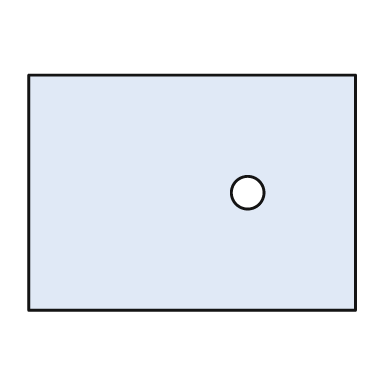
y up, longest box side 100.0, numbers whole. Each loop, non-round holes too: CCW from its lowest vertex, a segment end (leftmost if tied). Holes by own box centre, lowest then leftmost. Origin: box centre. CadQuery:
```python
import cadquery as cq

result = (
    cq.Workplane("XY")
    .moveTo(-50.0, -36.0)
    .lineTo(50.0, -36.0)
    .lineTo(50.0, 36.0)
    .lineTo(-50.0, 36.0)
    .close()
    .moveTo(17.0, 0.0)
    .circle(5.0)
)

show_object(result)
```